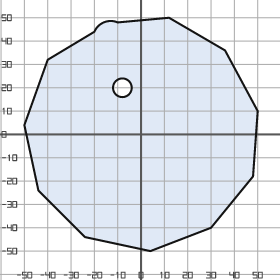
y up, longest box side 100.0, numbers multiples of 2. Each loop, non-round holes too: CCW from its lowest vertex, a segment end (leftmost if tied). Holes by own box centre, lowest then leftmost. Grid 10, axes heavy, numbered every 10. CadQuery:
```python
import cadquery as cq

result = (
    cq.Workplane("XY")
    .moveTo(4.0, -50.0)
    .lineTo(30.0, -40.0)
    .lineTo(48.0, -18.0)
    .lineTo(50.0, 10.0)
    .lineTo(36.0, 36.0)
    .lineTo(12.0, 50.0)
    .lineTo(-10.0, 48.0)
    .threePointArc((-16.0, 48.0), (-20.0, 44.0))
    .lineTo(-40.0, 32.0)
    .lineTo(-50.0, 4.0)
    .lineTo(-44.0, -24.0)
    .lineTo(-24.0, -44.0)
    .close()
    .moveTo(-8.0, 20.0)
    .circle(4.0)
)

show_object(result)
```